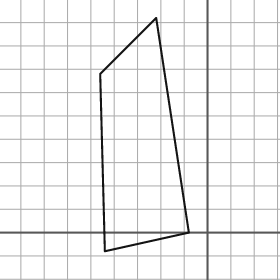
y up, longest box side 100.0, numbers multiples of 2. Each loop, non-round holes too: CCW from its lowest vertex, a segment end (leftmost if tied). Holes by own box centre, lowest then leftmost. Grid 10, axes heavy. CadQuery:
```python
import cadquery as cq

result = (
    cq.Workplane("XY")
    .moveTo(-44.0, -8.0)
    .lineTo(-8.0, 0.0)
    .lineTo(-22.0, 92.0)
    .lineTo(-46.0, 68.0)
    .close()
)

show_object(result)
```